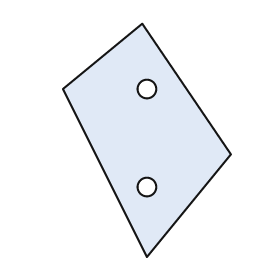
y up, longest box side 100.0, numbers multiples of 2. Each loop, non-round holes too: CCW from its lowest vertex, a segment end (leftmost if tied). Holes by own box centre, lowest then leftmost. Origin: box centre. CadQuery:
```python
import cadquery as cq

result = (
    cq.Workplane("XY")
    .moveTo(0.0, -50.0)
    .lineTo(36.0, -6.0)
    .lineTo(-2.0, 50.0)
    .lineTo(-36.0, 22.0)
    .close()
    .moveTo(0.0, -20.0)
    .circle(4.0)
    .moveTo(0.0, 22.0)
    .circle(4.0)
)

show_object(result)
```